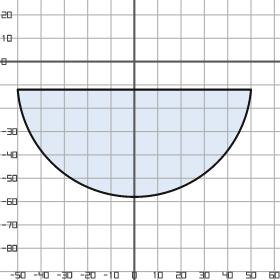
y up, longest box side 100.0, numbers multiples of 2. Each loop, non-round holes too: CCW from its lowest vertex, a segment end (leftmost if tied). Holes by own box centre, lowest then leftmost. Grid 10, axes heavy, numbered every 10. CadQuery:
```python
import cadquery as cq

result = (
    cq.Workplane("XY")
    .moveTo(-50.0, -12.0)
    .threePointArc((0.0, -58.0), (50.0, -12.0))
    .close()
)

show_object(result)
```